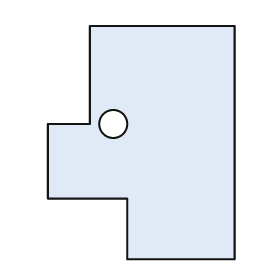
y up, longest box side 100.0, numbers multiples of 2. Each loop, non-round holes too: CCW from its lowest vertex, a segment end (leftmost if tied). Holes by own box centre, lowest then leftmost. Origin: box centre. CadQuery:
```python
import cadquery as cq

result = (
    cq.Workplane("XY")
    .moveTo(-6.0, -50.0)
    .lineTo(40.0, -50.0)
    .lineTo(40.0, 50.0)
    .lineTo(-22.0, 50.0)
    .lineTo(-22.0, 8.0)
    .lineTo(-40.0, 8.0)
    .lineTo(-40.0, -24.0)
    .lineTo(-6.0, -24.0)
    .close()
    .moveTo(-12.0, 8.0)
    .circle(6.0)
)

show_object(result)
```